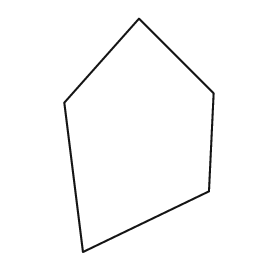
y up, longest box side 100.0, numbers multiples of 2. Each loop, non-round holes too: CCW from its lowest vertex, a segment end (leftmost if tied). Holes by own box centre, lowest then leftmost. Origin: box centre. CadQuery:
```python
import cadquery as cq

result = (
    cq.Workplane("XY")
    .moveTo(-24.0, -50.0)
    .lineTo(30.0, -24.0)
    .lineTo(32.0, 18.0)
    .lineTo(0.0, 50.0)
    .lineTo(-32.0, 14.0)
    .close()
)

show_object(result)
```